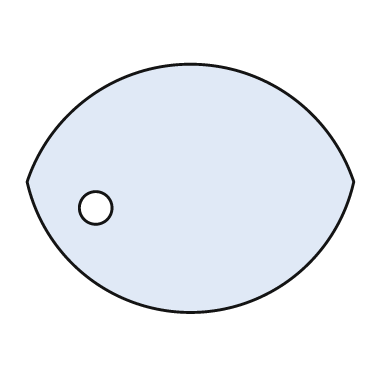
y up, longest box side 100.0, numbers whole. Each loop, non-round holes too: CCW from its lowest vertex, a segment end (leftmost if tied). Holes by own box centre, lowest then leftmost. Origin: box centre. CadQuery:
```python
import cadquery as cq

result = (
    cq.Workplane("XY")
    .moveTo(-50.0, 2.0)
    .threePointArc((0.0, -38.0), (50.0, 2.0))
    .threePointArc((0.0, 38.0), (-50.0, 2.0))
    .close()
    .moveTo(-29.0, -6.0)
    .circle(5.0)
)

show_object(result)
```